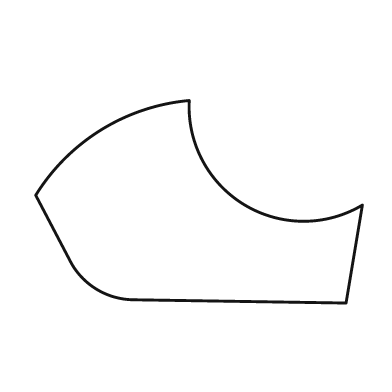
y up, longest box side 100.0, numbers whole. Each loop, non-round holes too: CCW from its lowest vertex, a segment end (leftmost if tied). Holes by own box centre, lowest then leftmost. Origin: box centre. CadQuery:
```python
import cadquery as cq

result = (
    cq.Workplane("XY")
    .moveTo(45.0, -31.0)
    .lineTo(50.0, -1.0)
    .threePointArc((14.0, -1.0), (-3.0, 31.0))
    .threePointArc((-30.0, 22.0), (-50.0, 2.0))
    .lineTo(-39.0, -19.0)
    .threePointArc((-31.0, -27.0), (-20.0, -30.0))
    .close()
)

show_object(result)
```